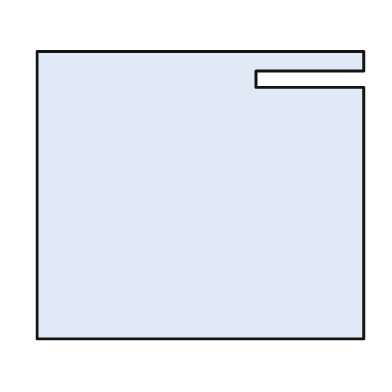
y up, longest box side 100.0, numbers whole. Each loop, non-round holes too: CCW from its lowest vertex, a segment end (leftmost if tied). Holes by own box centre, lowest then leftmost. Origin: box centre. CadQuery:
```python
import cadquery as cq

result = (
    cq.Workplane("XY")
    .moveTo(-50.0, -44.0)
    .lineTo(50.0, -44.0)
    .lineTo(50.0, 33.0)
    .lineTo(17.0, 33.0)
    .lineTo(17.0, 38.0)
    .lineTo(50.0, 38.0)
    .lineTo(50.0, 44.0)
    .lineTo(-50.0, 44.0)
    .close()
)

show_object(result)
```